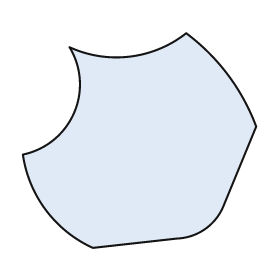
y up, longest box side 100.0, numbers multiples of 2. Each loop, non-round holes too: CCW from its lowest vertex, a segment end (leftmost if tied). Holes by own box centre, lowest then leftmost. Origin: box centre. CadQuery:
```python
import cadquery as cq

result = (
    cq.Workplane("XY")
    .moveTo(-20.0, -46.0)
    .lineTo(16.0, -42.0)
    .threePointArc((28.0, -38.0), (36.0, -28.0))
    .lineTo(50.0, 6.0)
    .threePointArc((38.0, 28.0), (20.0, 46.0))
    .threePointArc((-4.0, 36.0), (-30.0, 40.0))
    .threePointArc((-28.0, 12.0), (-50.0, -6.0))
    .threePointArc((-40.0, -30.0), (-20.0, -46.0))
    .close()
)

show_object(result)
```